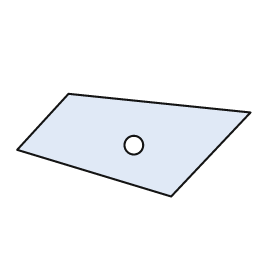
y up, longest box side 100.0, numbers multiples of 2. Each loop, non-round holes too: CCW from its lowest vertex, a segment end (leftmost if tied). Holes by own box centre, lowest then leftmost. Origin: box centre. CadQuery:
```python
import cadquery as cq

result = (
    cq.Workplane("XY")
    .moveTo(16.0, -22.0)
    .lineTo(50.0, 14.0)
    .lineTo(-28.0, 22.0)
    .lineTo(-50.0, -2.0)
    .close()
    .moveTo(0.0, 0.0)
    .circle(4.0)
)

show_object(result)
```